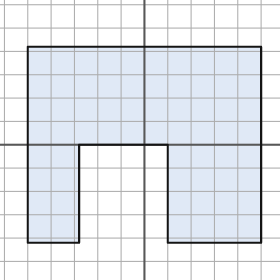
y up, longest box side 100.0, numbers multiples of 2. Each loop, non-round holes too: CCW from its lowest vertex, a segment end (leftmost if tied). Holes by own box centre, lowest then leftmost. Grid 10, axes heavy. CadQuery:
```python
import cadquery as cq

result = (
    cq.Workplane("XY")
    .moveTo(-50.0, -42.0)
    .lineTo(-28.0, -42.0)
    .lineTo(-28.0, 0.0)
    .lineTo(10.0, 0.0)
    .lineTo(10.0, -42.0)
    .lineTo(50.0, -42.0)
    .lineTo(50.0, 42.0)
    .lineTo(-50.0, 42.0)
    .close()
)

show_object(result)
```